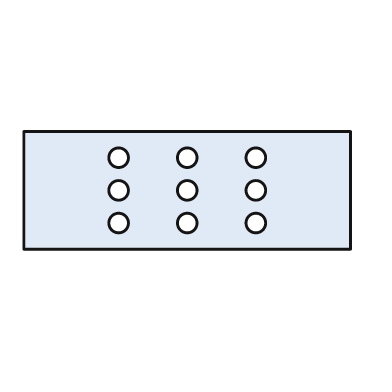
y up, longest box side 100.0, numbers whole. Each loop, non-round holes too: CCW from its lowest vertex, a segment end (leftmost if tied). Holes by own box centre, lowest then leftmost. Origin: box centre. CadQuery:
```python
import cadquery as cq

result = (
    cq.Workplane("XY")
    .moveTo(-50.0, -18.0)
    .lineTo(50.0, -18.0)
    .lineTo(50.0, 18.0)
    .lineTo(-50.0, 18.0)
    .close()
    .moveTo(-21.0, -10.0)
    .circle(3.0)
    .moveTo(0.0, -10.0)
    .circle(3.0)
    .moveTo(21.0, -10.0)
    .circle(3.0)
    .moveTo(-21.0, 0.0)
    .circle(3.0)
    .moveTo(0.0, 0.0)
    .circle(3.0)
    .moveTo(21.0, 0.0)
    .circle(3.0)
    .moveTo(-21.0, 10.0)
    .circle(3.0)
    .moveTo(0.0, 10.0)
    .circle(3.0)
    .moveTo(21.0, 10.0)
    .circle(3.0)
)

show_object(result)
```